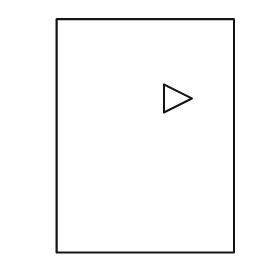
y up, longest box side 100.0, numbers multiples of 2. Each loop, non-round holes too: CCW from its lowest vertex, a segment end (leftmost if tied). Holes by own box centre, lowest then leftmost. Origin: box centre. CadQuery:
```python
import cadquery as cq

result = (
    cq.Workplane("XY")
    .moveTo(-38.0, -50.0)
    .lineTo(38.0, -50.0)
    .lineTo(38.0, 50.0)
    .lineTo(-38.0, 50.0)
    .close()
    .moveTo(8.0, 10.0)
    .lineTo(20.0, 16.0)
    .lineTo(8.0, 22.0)
    .close()
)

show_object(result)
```